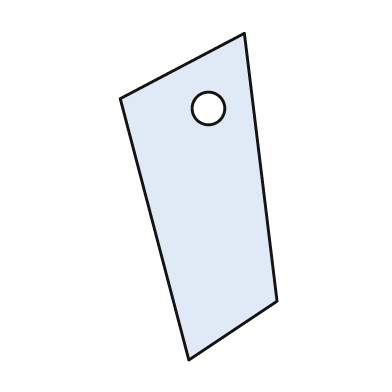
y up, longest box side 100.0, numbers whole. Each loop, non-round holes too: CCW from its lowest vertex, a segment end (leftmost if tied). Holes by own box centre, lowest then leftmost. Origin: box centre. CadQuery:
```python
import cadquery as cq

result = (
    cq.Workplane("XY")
    .moveTo(-3.0, -50.0)
    .lineTo(24.0, -32.0)
    .lineTo(14.0, 50.0)
    .lineTo(-24.0, 30.0)
    .close()
    .moveTo(3.0, 27.0)
    .circle(5.0)
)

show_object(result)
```